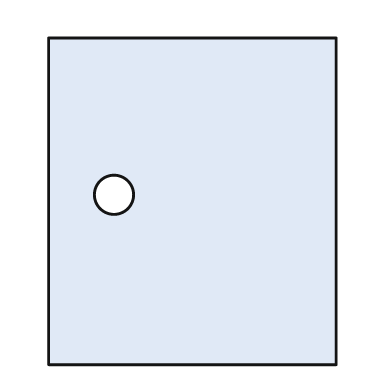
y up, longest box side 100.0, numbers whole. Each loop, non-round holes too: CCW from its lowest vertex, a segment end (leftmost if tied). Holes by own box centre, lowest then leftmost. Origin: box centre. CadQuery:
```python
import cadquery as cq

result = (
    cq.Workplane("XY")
    .moveTo(-44.0, -50.0)
    .lineTo(44.0, -50.0)
    .lineTo(44.0, 50.0)
    .lineTo(-44.0, 50.0)
    .close()
    .moveTo(-24.0, 2.0)
    .circle(6.0)
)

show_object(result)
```